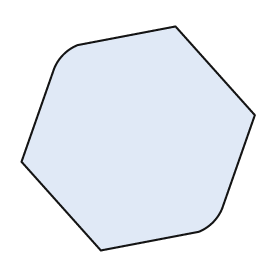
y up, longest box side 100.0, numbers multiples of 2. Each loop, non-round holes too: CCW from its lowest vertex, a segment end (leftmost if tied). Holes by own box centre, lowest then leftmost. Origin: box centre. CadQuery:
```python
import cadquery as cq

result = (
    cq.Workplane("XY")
    .moveTo(-16.0, -48.0)
    .lineTo(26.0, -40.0)
    .threePointArc((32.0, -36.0), (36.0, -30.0))
    .lineTo(50.0, 10.0)
    .lineTo(16.0, 48.0)
    .lineTo(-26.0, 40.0)
    .threePointArc((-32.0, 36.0), (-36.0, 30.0))
    .lineTo(-50.0, -10.0)
    .close()
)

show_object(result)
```